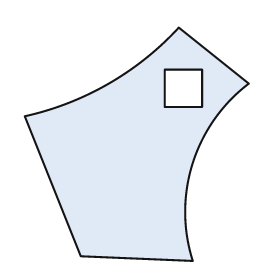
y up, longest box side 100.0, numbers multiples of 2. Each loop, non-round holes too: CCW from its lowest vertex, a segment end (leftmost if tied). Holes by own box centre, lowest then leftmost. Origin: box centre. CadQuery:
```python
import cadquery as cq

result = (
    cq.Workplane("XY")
    .moveTo(24.0, -50.0)
    .threePointArc((24.0, -8.0), (48.0, 26.0))
    .lineTo(18.0, 50.0)
    .threePointArc((-12.0, 26.0), (-48.0, 12.0))
    .lineTo(-24.0, -48.0)
    .close()
    .moveTo(12.0, 16.0)
    .lineTo(28.0, 16.0)
    .lineTo(28.0, 32.0)
    .lineTo(12.0, 32.0)
    .close()
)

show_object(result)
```